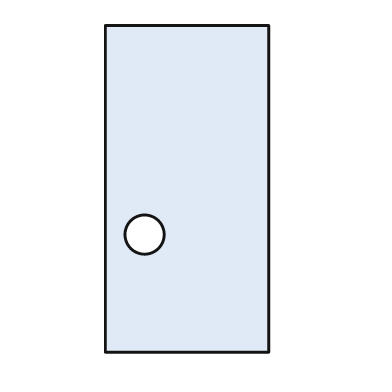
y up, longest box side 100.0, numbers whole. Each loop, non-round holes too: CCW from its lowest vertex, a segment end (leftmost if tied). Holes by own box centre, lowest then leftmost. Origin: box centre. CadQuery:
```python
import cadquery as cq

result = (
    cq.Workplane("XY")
    .moveTo(-25.0, -50.0)
    .lineTo(25.0, -50.0)
    .lineTo(25.0, 50.0)
    .lineTo(-25.0, 50.0)
    .close()
    .moveTo(-13.0, -14.0)
    .circle(6.0)
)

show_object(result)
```